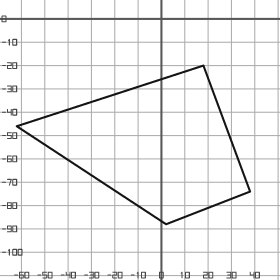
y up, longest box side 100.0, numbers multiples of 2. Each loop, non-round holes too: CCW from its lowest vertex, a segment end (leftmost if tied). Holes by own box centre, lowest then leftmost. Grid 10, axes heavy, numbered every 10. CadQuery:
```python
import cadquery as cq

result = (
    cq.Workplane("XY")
    .moveTo(2.0, -88.0)
    .lineTo(38.0, -74.0)
    .lineTo(18.0, -20.0)
    .lineTo(-62.0, -46.0)
    .close()
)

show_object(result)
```